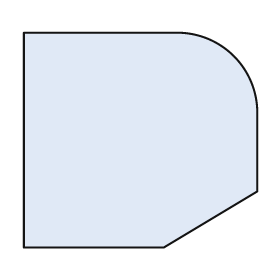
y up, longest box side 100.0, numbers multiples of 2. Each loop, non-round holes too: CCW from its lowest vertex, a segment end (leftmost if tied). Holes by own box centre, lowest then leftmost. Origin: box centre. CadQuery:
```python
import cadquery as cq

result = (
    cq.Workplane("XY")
    .moveTo(-50.0, -46.0)
    .lineTo(10.0, -46.0)
    .lineTo(50.0, -22.0)
    .lineTo(50.0, 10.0)
    .threePointArc((40.0, 36.0), (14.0, 46.0))
    .lineTo(-50.0, 46.0)
    .close()
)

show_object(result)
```